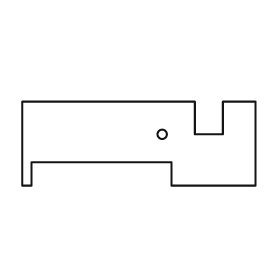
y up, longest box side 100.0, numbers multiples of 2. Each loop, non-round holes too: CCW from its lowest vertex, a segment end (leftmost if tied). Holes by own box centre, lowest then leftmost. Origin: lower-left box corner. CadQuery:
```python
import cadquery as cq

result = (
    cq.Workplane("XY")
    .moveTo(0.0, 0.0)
    .lineTo(4.0, 0.0)
    .lineTo(4.0, 10.0)
    .lineTo(64.0, 10.0)
    .lineTo(64.0, 0.0)
    .lineTo(100.0, 0.0)
    .lineTo(100.0, 36.0)
    .lineTo(86.0, 36.0)
    .lineTo(86.0, 22.0)
    .lineTo(74.0, 22.0)
    .lineTo(74.0, 36.0)
    .lineTo(0.0, 36.0)
    .close()
    .moveTo(60.0, 22.0)
    .circle(2.0)
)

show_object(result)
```